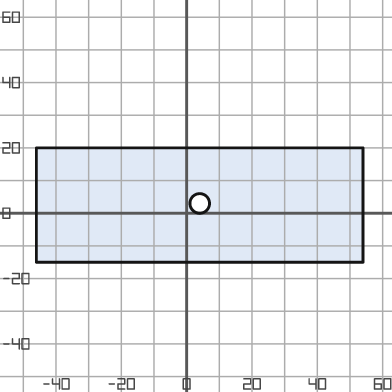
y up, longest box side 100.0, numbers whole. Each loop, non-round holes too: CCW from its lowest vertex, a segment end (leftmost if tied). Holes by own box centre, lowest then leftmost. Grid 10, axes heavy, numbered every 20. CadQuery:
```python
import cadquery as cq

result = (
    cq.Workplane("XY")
    .moveTo(-46.0, -15.0)
    .lineTo(54.0, -15.0)
    .lineTo(54.0, 20.0)
    .lineTo(-46.0, 20.0)
    .close()
    .moveTo(4.0, 3.0)
    .circle(3.0)
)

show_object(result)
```